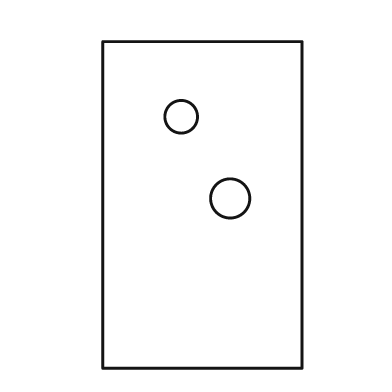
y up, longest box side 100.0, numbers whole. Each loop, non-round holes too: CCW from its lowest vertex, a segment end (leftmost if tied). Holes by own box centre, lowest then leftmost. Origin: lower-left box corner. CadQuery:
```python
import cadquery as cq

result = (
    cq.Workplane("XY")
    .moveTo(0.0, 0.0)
    .lineTo(61.0, 0.0)
    .lineTo(61.0, 100.0)
    .lineTo(0.0, 100.0)
    .close()
    .moveTo(39.0, 52.0)
    .circle(6.0)
    .moveTo(24.0, 77.0)
    .circle(5.0)
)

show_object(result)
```